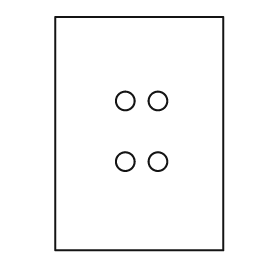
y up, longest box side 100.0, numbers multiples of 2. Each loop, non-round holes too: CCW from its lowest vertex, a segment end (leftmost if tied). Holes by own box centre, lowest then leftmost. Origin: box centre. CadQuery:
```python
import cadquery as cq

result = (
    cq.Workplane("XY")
    .moveTo(-36.0, -50.0)
    .lineTo(36.0, -50.0)
    .lineTo(36.0, 50.0)
    .lineTo(-36.0, 50.0)
    .close()
    .moveTo(-6.0, -12.0)
    .circle(4.0)
    .moveTo(8.0, -12.0)
    .circle(4.0)
    .moveTo(-6.0, 14.0)
    .circle(4.0)
    .moveTo(8.0, 14.0)
    .circle(4.0)
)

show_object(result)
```